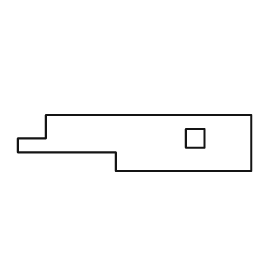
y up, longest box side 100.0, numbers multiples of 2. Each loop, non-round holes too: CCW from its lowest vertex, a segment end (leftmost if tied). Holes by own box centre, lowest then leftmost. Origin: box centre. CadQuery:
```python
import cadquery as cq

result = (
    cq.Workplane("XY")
    .moveTo(-8.0, -12.0)
    .lineTo(50.0, -12.0)
    .lineTo(50.0, 12.0)
    .lineTo(-38.0, 12.0)
    .lineTo(-38.0, 2.0)
    .lineTo(-50.0, 2.0)
    .lineTo(-50.0, -4.0)
    .lineTo(-8.0, -4.0)
    .close()
    .moveTo(22.0, -2.0)
    .lineTo(30.0, -2.0)
    .lineTo(30.0, 6.0)
    .lineTo(22.0, 6.0)
    .close()
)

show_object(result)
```